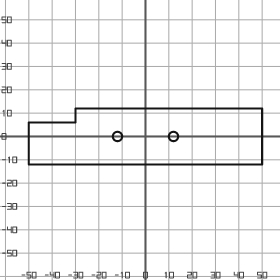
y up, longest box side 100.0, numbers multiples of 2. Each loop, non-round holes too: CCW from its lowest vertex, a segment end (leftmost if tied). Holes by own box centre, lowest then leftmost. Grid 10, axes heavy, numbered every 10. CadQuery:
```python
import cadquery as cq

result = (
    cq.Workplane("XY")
    .moveTo(-50.0, -12.0)
    .lineTo(50.0, -12.0)
    .lineTo(50.0, 12.0)
    .lineTo(-30.0, 12.0)
    .lineTo(-30.0, 6.0)
    .lineTo(-50.0, 6.0)
    .close()
    .moveTo(-12.0, 0.0)
    .circle(2.0)
    .moveTo(12.0, 0.0)
    .circle(2.0)
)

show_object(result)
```